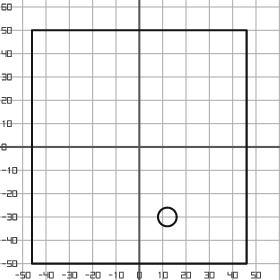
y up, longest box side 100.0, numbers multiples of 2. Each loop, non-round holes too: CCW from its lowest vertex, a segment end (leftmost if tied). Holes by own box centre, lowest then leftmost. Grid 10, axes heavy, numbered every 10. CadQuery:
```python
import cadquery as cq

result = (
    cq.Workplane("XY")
    .moveTo(-46.0, -50.0)
    .lineTo(46.0, -50.0)
    .lineTo(46.0, 50.0)
    .lineTo(-46.0, 50.0)
    .close()
    .moveTo(12.0, -30.0)
    .circle(4.0)
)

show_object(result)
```